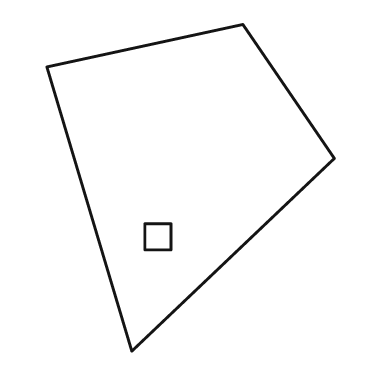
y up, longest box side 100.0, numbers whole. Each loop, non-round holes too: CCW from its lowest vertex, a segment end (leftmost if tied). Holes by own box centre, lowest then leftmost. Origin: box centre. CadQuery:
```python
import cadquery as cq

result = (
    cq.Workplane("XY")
    .moveTo(-18.0, -50.0)
    .lineTo(44.0, 9.0)
    .lineTo(16.0, 50.0)
    .lineTo(-44.0, 37.0)
    .close()
    .moveTo(-14.0, -19.0)
    .lineTo(-6.0, -19.0)
    .lineTo(-6.0, -11.0)
    .lineTo(-14.0, -11.0)
    .close()
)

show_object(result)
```